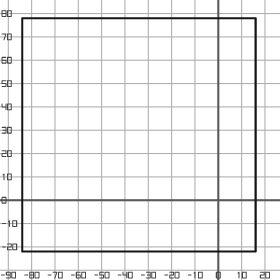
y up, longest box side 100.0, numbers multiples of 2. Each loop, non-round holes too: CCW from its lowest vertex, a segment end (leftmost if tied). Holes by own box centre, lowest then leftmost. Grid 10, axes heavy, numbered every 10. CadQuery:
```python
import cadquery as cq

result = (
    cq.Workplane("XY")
    .moveTo(-84.0, -22.0)
    .lineTo(16.0, -22.0)
    .lineTo(16.0, 78.0)
    .lineTo(-84.0, 78.0)
    .close()
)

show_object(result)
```